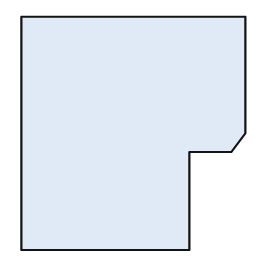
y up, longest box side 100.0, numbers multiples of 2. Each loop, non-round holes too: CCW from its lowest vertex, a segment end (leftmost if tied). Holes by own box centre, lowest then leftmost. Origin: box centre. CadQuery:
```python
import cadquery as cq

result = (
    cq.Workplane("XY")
    .moveTo(-48.0, -50.0)
    .lineTo(24.0, -50.0)
    .lineTo(24.0, -8.0)
    .lineTo(42.0, -8.0)
    .lineTo(48.0, 0.0)
    .lineTo(48.0, 50.0)
    .lineTo(-48.0, 50.0)
    .close()
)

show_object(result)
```